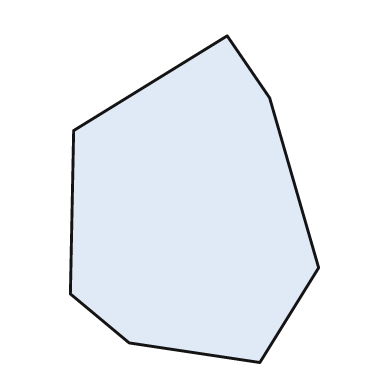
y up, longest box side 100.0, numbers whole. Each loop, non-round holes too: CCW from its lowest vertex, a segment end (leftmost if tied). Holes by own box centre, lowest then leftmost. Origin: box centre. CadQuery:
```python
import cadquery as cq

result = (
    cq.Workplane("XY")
    .moveTo(20.0, -50.0)
    .lineTo(38.0, -21.0)
    .lineTo(23.0, 31.0)
    .lineTo(10.0, 50.0)
    .lineTo(-37.0, 21.0)
    .lineTo(-38.0, -29.0)
    .lineTo(-20.0, -44.0)
    .close()
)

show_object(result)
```